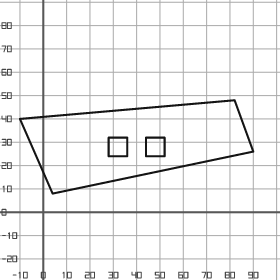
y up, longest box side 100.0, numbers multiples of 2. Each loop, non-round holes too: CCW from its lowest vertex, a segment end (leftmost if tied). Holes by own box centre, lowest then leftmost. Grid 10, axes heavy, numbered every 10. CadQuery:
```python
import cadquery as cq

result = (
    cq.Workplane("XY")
    .moveTo(4.0, 8.0)
    .lineTo(90.0, 26.0)
    .lineTo(82.0, 48.0)
    .lineTo(-10.0, 40.0)
    .close()
    .moveTo(28.0, 24.0)
    .lineTo(36.0, 24.0)
    .lineTo(36.0, 32.0)
    .lineTo(28.0, 32.0)
    .close()
    .moveTo(44.0, 24.0)
    .lineTo(52.0, 24.0)
    .lineTo(52.0, 32.0)
    .lineTo(44.0, 32.0)
    .close()
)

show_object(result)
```